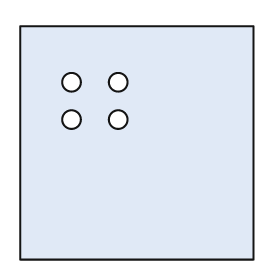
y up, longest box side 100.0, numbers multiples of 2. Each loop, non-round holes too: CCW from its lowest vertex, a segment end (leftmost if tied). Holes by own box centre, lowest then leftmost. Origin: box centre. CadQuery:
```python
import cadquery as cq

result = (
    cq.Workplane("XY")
    .moveTo(-50.0, -50.0)
    .lineTo(50.0, -50.0)
    .lineTo(50.0, 50.0)
    .lineTo(-50.0, 50.0)
    .close()
    .moveTo(-28.0, 10.0)
    .circle(4.0)
    .moveTo(-8.0, 10.0)
    .circle(4.0)
    .moveTo(-28.0, 26.0)
    .circle(4.0)
    .moveTo(-8.0, 26.0)
    .circle(4.0)
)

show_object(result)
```